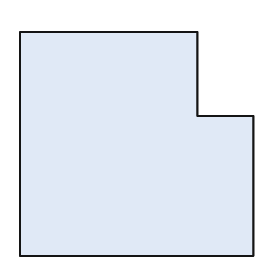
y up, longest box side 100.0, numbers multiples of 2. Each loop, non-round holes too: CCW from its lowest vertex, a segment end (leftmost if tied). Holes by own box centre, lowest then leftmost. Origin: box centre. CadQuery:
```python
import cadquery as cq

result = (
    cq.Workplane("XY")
    .moveTo(-50.0, -48.0)
    .lineTo(50.0, -48.0)
    .lineTo(50.0, 12.0)
    .lineTo(26.0, 12.0)
    .lineTo(26.0, 48.0)
    .lineTo(-50.0, 48.0)
    .close()
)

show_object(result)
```